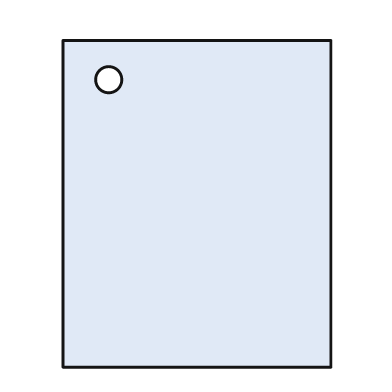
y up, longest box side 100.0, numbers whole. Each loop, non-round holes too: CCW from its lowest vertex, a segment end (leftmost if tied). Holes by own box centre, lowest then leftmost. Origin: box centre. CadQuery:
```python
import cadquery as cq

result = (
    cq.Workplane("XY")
    .moveTo(-41.0, -50.0)
    .lineTo(41.0, -50.0)
    .lineTo(41.0, 50.0)
    .lineTo(-41.0, 50.0)
    .close()
    .moveTo(-27.0, 38.0)
    .circle(4.0)
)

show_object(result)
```